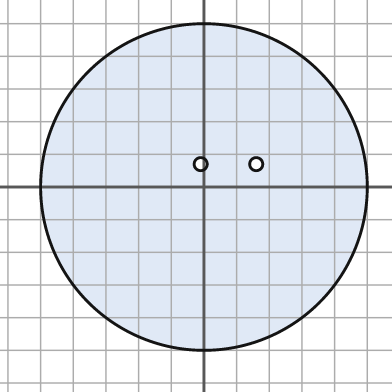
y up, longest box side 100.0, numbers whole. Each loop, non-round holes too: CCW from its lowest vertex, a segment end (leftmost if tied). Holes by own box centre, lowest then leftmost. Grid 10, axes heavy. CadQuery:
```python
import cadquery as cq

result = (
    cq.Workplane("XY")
    .moveTo(0.0, 0.0)
    .circle(50.0)
    .moveTo(-1.0, 7.0)
    .circle(2.0)
    .moveTo(16.0, 7.0)
    .circle(2.0)
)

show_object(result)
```